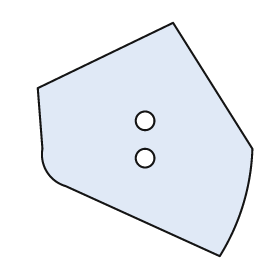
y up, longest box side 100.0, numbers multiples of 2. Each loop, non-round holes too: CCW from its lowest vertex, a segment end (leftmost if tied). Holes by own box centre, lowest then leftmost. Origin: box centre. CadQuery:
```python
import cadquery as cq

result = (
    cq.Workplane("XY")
    .moveTo(32.0, -50.0)
    .threePointArc((42.0, -28.0), (46.0, -4.0))
    .lineTo(12.0, 50.0)
    .lineTo(-46.0, 22.0)
    .lineTo(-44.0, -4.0)
    .threePointArc((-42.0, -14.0), (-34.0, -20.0))
    .close()
    .moveTo(0.0, -8.0)
    .circle(4.0)
    .moveTo(0.0, 8.0)
    .circle(4.0)
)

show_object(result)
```